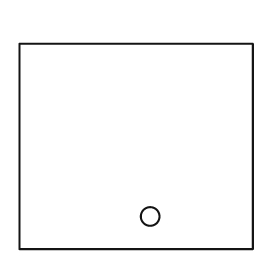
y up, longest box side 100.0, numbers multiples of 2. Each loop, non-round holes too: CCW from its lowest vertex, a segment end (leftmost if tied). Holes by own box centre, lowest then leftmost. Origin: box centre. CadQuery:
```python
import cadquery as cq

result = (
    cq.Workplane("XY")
    .moveTo(-50.0, -44.0)
    .lineTo(50.0, -44.0)
    .lineTo(50.0, 44.0)
    .lineTo(-50.0, 44.0)
    .close()
    .moveTo(6.0, -30.0)
    .circle(4.0)
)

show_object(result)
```